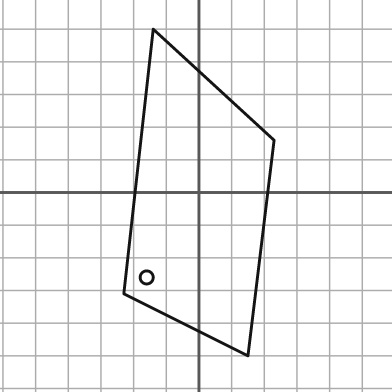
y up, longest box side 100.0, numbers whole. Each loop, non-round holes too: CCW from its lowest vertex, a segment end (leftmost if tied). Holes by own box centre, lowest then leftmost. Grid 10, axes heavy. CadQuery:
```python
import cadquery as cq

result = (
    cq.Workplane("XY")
    .moveTo(15.0, -50.0)
    .lineTo(23.0, 16.0)
    .lineTo(-14.0, 50.0)
    .lineTo(-23.0, -31.0)
    .close()
    .moveTo(-16.0, -26.0)
    .circle(2.0)
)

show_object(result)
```